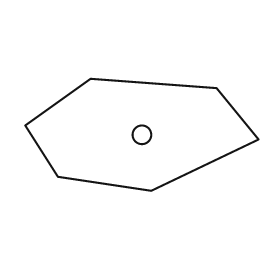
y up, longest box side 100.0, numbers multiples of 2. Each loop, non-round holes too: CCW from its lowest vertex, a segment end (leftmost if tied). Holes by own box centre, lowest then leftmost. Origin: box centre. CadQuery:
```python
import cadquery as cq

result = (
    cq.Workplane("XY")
    .moveTo(4.0, -24.0)
    .lineTo(50.0, -2.0)
    .lineTo(32.0, 20.0)
    .lineTo(-22.0, 24.0)
    .lineTo(-50.0, 4.0)
    .lineTo(-36.0, -18.0)
    .close()
    .moveTo(0.0, 0.0)
    .circle(4.0)
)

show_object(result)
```